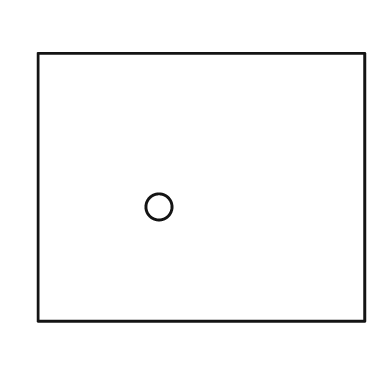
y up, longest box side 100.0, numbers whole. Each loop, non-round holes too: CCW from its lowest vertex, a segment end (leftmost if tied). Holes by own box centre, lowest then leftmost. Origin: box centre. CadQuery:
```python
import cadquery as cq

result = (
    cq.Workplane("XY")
    .moveTo(-50.0, -41.0)
    .lineTo(50.0, -41.0)
    .lineTo(50.0, 41.0)
    .lineTo(-50.0, 41.0)
    .close()
    .moveTo(-13.0, -6.0)
    .circle(4.0)
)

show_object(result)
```